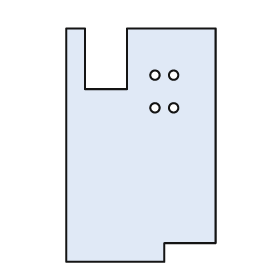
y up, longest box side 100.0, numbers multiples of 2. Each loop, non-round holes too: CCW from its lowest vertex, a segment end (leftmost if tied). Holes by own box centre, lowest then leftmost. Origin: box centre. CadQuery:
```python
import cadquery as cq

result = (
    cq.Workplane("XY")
    .moveTo(-32.0, -50.0)
    .lineTo(10.0, -50.0)
    .lineTo(10.0, -42.0)
    .lineTo(32.0, -42.0)
    .lineTo(32.0, 50.0)
    .lineTo(-6.0, 50.0)
    .lineTo(-6.0, 24.0)
    .lineTo(-24.0, 24.0)
    .lineTo(-24.0, 50.0)
    .lineTo(-32.0, 50.0)
    .close()
    .moveTo(6.0, 16.0)
    .circle(2.0)
    .moveTo(14.0, 16.0)
    .circle(2.0)
    .moveTo(6.0, 30.0)
    .circle(2.0)
    .moveTo(14.0, 30.0)
    .circle(2.0)
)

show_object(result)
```